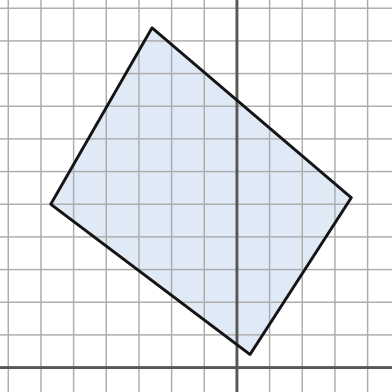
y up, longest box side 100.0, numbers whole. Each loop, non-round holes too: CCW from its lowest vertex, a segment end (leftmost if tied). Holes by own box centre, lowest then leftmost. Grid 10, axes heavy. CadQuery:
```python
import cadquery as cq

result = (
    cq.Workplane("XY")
    .moveTo(4.0, 4.0)
    .lineTo(35.0, 52.0)
    .lineTo(-26.0, 104.0)
    .lineTo(-57.0, 50.0)
    .close()
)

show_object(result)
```